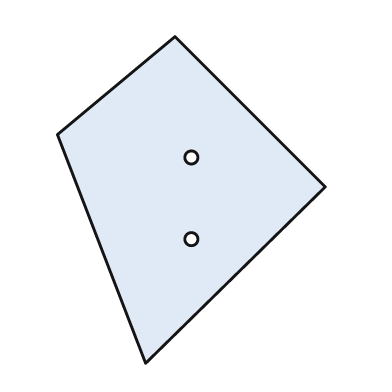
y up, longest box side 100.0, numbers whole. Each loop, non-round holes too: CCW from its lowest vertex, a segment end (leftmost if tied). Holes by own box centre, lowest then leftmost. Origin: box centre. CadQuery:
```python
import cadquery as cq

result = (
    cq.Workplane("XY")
    .moveTo(-14.0, -50.0)
    .lineTo(41.0, 4.0)
    .lineTo(-5.0, 50.0)
    .lineTo(-41.0, 20.0)
    .close()
    .moveTo(0.0, -12.0)
    .circle(2.0)
    .moveTo(0.0, 13.0)
    .circle(2.0)
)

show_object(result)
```